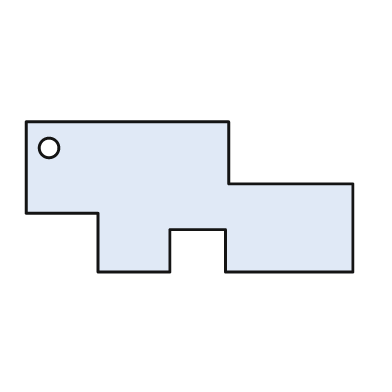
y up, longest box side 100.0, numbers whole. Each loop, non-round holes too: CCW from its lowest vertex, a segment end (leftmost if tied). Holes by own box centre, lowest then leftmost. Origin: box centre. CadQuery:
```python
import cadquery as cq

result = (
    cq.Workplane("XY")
    .moveTo(-28.0, -23.0)
    .lineTo(-6.0, -23.0)
    .lineTo(-6.0, -10.0)
    .lineTo(11.0, -10.0)
    .lineTo(11.0, -23.0)
    .lineTo(50.0, -23.0)
    .lineTo(50.0, 4.0)
    .lineTo(12.0, 4.0)
    .lineTo(12.0, 23.0)
    .lineTo(-50.0, 23.0)
    .lineTo(-50.0, -5.0)
    .lineTo(-28.0, -5.0)
    .close()
    .moveTo(-43.0, 15.0)
    .circle(3.0)
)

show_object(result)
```